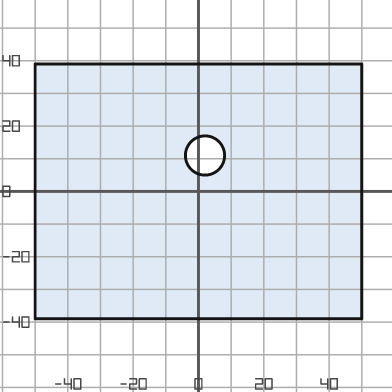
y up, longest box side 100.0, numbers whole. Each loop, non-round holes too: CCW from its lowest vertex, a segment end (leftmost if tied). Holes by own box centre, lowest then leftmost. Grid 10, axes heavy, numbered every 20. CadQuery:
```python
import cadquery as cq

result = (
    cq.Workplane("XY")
    .moveTo(-50.0, -39.0)
    .lineTo(50.0, -39.0)
    .lineTo(50.0, 39.0)
    .lineTo(-50.0, 39.0)
    .close()
    .moveTo(2.0, 11.0)
    .circle(6.0)
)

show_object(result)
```